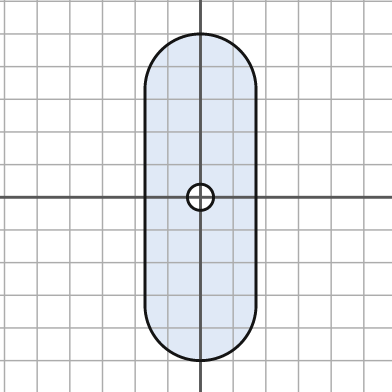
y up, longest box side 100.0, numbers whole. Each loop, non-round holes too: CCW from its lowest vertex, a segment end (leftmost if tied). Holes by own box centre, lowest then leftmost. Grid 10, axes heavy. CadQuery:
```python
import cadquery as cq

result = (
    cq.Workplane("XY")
    .moveTo(-17.0, -33.0)
    .threePointArc((0.0, -50.0), (17.0, -33.0))
    .lineTo(17.0, 33.0)
    .threePointArc((0.0, 50.0), (-17.0, 33.0))
    .close()
    .moveTo(0.0, 0.0)
    .circle(4.0)
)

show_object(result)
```